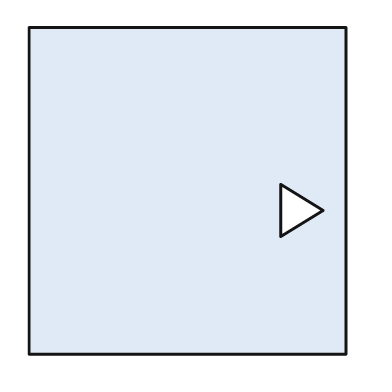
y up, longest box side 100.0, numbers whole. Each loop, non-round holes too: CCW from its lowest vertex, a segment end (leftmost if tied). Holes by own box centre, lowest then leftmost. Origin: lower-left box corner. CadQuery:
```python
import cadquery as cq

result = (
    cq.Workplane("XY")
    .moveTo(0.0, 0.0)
    .lineTo(97.0, 0.0)
    .lineTo(97.0, 100.0)
    .lineTo(0.0, 100.0)
    .close()
    .moveTo(77.0, 36.0)
    .lineTo(90.0, 44.0)
    .lineTo(77.0, 52.0)
    .close()
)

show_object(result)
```